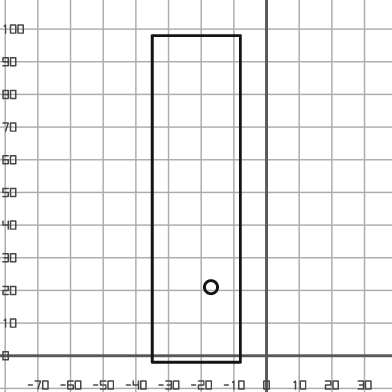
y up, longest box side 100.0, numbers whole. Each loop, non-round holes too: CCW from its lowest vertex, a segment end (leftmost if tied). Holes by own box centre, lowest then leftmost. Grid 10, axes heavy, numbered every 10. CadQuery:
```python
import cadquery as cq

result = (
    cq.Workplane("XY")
    .moveTo(-35.0, -2.0)
    .lineTo(-8.0, -2.0)
    .lineTo(-8.0, 98.0)
    .lineTo(-35.0, 98.0)
    .close()
    .moveTo(-17.0, 21.0)
    .circle(2.0)
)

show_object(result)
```